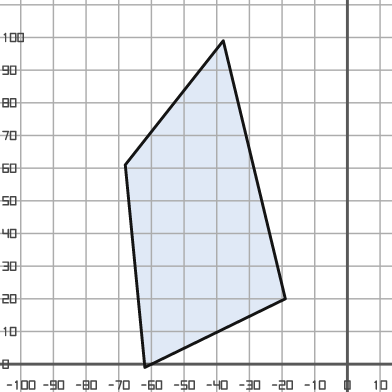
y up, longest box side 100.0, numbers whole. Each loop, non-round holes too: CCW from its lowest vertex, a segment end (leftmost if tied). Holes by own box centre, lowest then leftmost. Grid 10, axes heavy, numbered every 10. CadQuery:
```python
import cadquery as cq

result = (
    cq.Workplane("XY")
    .moveTo(-62.0, -1.0)
    .lineTo(-19.0, 20.0)
    .lineTo(-38.0, 99.0)
    .lineTo(-68.0, 61.0)
    .close()
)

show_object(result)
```